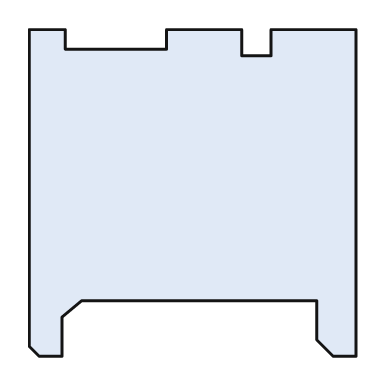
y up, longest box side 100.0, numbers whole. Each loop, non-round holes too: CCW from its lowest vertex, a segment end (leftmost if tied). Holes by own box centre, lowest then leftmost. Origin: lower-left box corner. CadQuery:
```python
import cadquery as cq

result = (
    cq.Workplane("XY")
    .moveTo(3.0, 0.0)
    .lineTo(10.0, 0.0)
    .lineTo(10.0, 12.0)
    .lineTo(16.0, 17.0)
    .lineTo(88.0, 17.0)
    .lineTo(88.0, 5.0)
    .lineTo(93.0, 0.0)
    .lineTo(100.0, 0.0)
    .lineTo(100.0, 100.0)
    .lineTo(74.0, 100.0)
    .lineTo(74.0, 92.0)
    .lineTo(65.0, 92.0)
    .lineTo(65.0, 100.0)
    .lineTo(42.0, 100.0)
    .lineTo(42.0, 94.0)
    .lineTo(11.0, 94.0)
    .lineTo(11.0, 100.0)
    .lineTo(0.0, 100.0)
    .lineTo(0.0, 3.0)
    .close()
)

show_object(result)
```